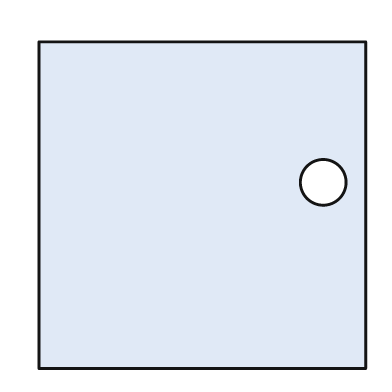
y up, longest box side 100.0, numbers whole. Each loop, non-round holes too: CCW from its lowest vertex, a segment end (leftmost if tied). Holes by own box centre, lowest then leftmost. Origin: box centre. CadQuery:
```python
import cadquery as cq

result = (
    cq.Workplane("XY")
    .moveTo(-50.0, -50.0)
    .lineTo(50.0, -50.0)
    .lineTo(50.0, 50.0)
    .lineTo(-50.0, 50.0)
    .close()
    .moveTo(37.0, 7.0)
    .circle(7.0)
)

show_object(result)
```